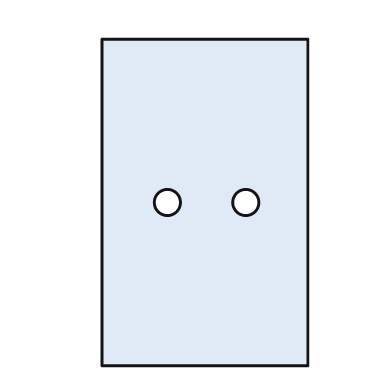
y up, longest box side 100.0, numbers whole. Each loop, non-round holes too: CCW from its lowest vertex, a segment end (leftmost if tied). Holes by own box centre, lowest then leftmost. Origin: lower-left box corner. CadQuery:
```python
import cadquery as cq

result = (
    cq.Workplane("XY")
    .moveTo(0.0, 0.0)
    .lineTo(63.0, 0.0)
    .lineTo(63.0, 100.0)
    .lineTo(0.0, 100.0)
    .close()
    .moveTo(20.0, 50.0)
    .circle(4.0)
    .moveTo(44.0, 50.0)
    .circle(4.0)
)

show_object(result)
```